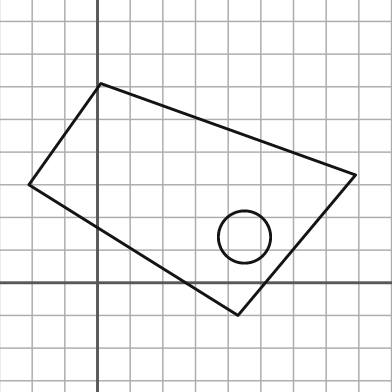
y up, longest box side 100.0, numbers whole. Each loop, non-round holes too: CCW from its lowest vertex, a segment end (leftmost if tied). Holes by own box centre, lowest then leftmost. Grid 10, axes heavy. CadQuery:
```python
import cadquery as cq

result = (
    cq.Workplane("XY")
    .moveTo(43.0, -10.0)
    .lineTo(79.0, 33.0)
    .lineTo(1.0, 61.0)
    .lineTo(-21.0, 30.0)
    .close()
    .moveTo(45.0, 14.0)
    .circle(8.0)
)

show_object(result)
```